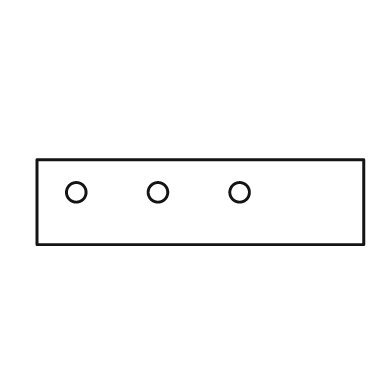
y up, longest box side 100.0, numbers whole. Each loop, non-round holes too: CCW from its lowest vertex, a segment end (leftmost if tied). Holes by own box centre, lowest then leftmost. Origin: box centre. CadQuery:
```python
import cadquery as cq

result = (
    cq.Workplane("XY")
    .moveTo(-50.0, -13.0)
    .lineTo(50.0, -13.0)
    .lineTo(50.0, 13.0)
    .lineTo(-50.0, 13.0)
    .close()
    .moveTo(-38.0, 3.0)
    .circle(3.0)
    .moveTo(-13.0, 3.0)
    .circle(3.0)
    .moveTo(12.0, 3.0)
    .circle(3.0)
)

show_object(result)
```